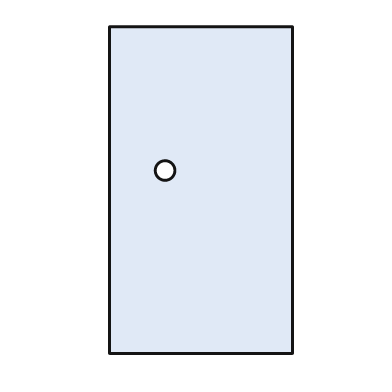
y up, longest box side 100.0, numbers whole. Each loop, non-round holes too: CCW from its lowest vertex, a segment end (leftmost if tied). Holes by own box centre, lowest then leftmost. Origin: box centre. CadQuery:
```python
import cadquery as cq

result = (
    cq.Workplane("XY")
    .moveTo(-28.0, -50.0)
    .lineTo(28.0, -50.0)
    .lineTo(28.0, 50.0)
    .lineTo(-28.0, 50.0)
    .close()
    .moveTo(-11.0, 6.0)
    .circle(3.0)
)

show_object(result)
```